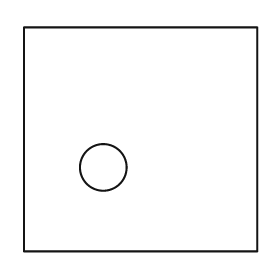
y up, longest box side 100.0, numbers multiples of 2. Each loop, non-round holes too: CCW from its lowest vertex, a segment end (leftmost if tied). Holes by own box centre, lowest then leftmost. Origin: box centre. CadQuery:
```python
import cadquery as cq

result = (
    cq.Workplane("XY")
    .moveTo(-50.0, -48.0)
    .lineTo(50.0, -48.0)
    .lineTo(50.0, 48.0)
    .lineTo(-50.0, 48.0)
    .close()
    .moveTo(-16.0, -12.0)
    .circle(10.0)
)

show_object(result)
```